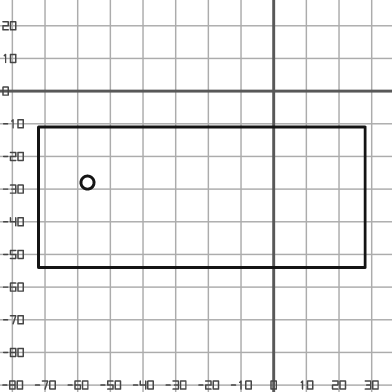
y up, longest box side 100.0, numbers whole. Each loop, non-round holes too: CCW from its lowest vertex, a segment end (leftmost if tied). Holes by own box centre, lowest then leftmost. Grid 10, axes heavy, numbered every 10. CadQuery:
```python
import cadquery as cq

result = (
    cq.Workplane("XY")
    .moveTo(-72.0, -54.0)
    .lineTo(28.0, -54.0)
    .lineTo(28.0, -11.0)
    .lineTo(-72.0, -11.0)
    .close()
    .moveTo(-57.0, -28.0)
    .circle(2.0)
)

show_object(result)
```